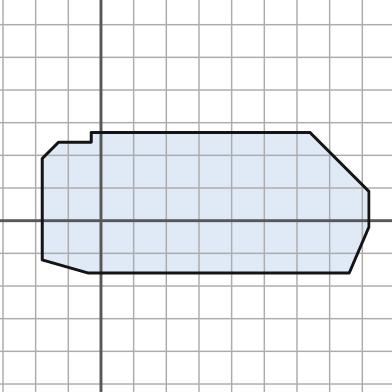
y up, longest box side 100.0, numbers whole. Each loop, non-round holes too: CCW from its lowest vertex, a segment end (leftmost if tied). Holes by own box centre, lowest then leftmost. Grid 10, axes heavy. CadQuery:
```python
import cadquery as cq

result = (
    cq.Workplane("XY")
    .moveTo(-4.0, -16.0)
    .lineTo(76.0, -16.0)
    .lineTo(82.0, -2.0)
    .lineTo(82.0, 9.0)
    .lineTo(64.0, 27.0)
    .lineTo(-3.0, 27.0)
    .lineTo(-3.0, 24.0)
    .lineTo(-13.0, 24.0)
    .lineTo(-18.0, 19.0)
    .lineTo(-18.0, -12.0)
    .close()
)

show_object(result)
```